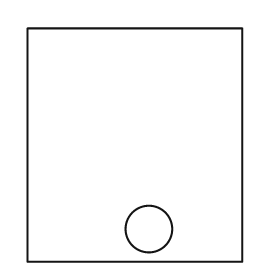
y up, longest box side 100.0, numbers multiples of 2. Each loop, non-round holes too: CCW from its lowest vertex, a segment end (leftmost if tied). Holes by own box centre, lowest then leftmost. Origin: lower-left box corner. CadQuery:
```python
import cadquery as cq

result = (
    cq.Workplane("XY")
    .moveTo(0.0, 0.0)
    .lineTo(92.0, 0.0)
    .lineTo(92.0, 100.0)
    .lineTo(0.0, 100.0)
    .close()
    .moveTo(52.0, 14.0)
    .circle(10.0)
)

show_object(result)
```